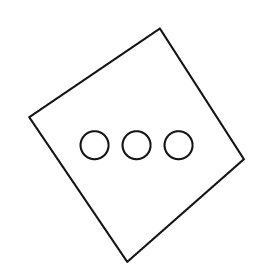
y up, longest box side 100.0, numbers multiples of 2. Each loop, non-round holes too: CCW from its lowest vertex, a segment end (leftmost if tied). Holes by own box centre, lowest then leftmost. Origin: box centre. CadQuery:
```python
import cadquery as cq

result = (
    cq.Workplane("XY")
    .moveTo(-4.0, -50.0)
    .lineTo(46.0, -6.0)
    .lineTo(10.0, 50.0)
    .lineTo(-46.0, 12.0)
    .close()
    .moveTo(-18.0, 0.0)
    .circle(6.0)
    .moveTo(0.0, 0.0)
    .circle(6.0)
    .moveTo(18.0, 0.0)
    .circle(6.0)
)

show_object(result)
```